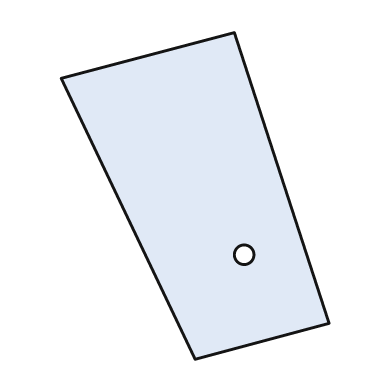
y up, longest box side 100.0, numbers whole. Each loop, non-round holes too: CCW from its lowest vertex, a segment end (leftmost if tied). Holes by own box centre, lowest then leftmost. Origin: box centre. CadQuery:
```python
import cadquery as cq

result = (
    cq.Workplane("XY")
    .moveTo(0.0, -50.0)
    .lineTo(41.0, -39.0)
    .lineTo(12.0, 50.0)
    .lineTo(-41.0, 36.0)
    .close()
    .moveTo(15.0, -18.0)
    .circle(3.0)
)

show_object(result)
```